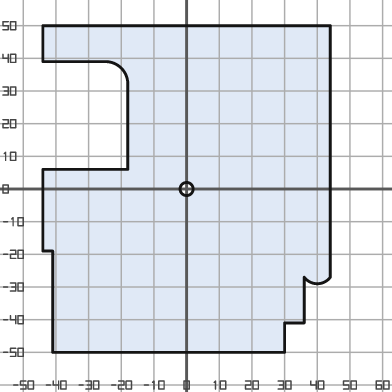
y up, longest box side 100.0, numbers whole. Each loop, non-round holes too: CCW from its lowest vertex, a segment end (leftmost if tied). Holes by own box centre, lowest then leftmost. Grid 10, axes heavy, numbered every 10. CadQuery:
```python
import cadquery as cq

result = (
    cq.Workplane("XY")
    .moveTo(-41.0, -50.0)
    .lineTo(30.0, -50.0)
    .lineTo(30.0, -41.0)
    .lineTo(36.0, -41.0)
    .lineTo(36.0, -27.0)
    .threePointArc((40.0, -29.0), (44.0, -27.0))
    .lineTo(44.0, 50.0)
    .lineTo(-44.0, 50.0)
    .lineTo(-44.0, 39.0)
    .lineTo(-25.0, 39.0)
    .threePointArc((-20.0, 37.0), (-18.0, 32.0))
    .lineTo(-18.0, 6.0)
    .lineTo(-44.0, 6.0)
    .lineTo(-44.0, -19.0)
    .lineTo(-41.0, -19.0)
    .close()
    .moveTo(0.0, 0.0)
    .circle(2.0)
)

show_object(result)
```